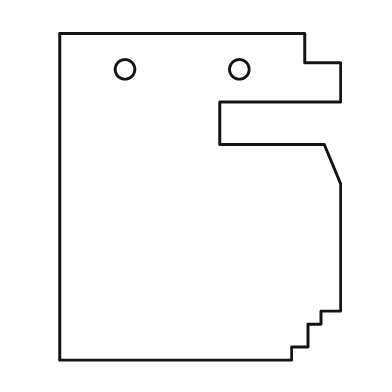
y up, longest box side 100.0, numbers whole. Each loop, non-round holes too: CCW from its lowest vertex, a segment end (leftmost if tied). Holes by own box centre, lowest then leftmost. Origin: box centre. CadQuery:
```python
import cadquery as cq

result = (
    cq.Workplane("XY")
    .moveTo(-43.0, -50.0)
    .lineTo(28.0, -50.0)
    .lineTo(28.0, -46.0)
    .lineTo(33.0, -46.0)
    .lineTo(33.0, -39.0)
    .lineTo(37.0, -39.0)
    .lineTo(37.0, -35.0)
    .lineTo(43.0, -35.0)
    .lineTo(43.0, 4.0)
    .lineTo(38.0, 16.0)
    .lineTo(6.0, 16.0)
    .lineTo(6.0, 29.0)
    .lineTo(43.0, 29.0)
    .lineTo(43.0, 41.0)
    .lineTo(32.0, 41.0)
    .lineTo(32.0, 50.0)
    .lineTo(-43.0, 50.0)
    .close()
    .moveTo(-23.0, 39.0)
    .circle(3.0)
    .moveTo(12.0, 39.0)
    .circle(3.0)
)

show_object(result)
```